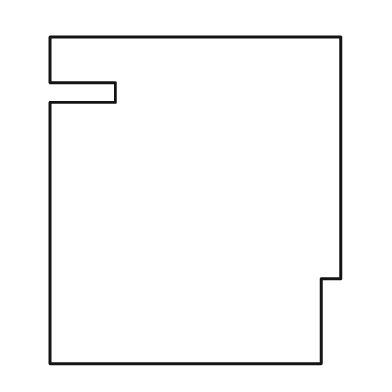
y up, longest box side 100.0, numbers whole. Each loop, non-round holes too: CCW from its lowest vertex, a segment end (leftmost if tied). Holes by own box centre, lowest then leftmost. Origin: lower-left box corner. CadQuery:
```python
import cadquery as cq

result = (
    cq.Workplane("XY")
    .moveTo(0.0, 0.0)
    .lineTo(83.0, 0.0)
    .lineTo(83.0, 26.0)
    .lineTo(89.0, 26.0)
    .lineTo(89.0, 100.0)
    .lineTo(0.0, 100.0)
    .lineTo(0.0, 86.0)
    .lineTo(20.0, 86.0)
    .lineTo(20.0, 80.0)
    .lineTo(0.0, 80.0)
    .close()
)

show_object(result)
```